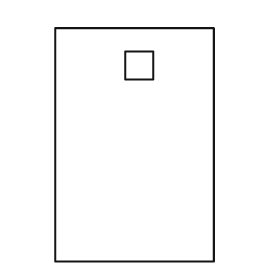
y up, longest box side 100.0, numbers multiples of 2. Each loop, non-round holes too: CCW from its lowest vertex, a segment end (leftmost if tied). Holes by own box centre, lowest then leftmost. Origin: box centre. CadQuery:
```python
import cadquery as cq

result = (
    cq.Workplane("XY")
    .moveTo(-34.0, -50.0)
    .lineTo(34.0, -50.0)
    .lineTo(34.0, 50.0)
    .lineTo(-34.0, 50.0)
    .close()
    .moveTo(-4.0, 28.0)
    .lineTo(8.0, 28.0)
    .lineTo(8.0, 40.0)
    .lineTo(-4.0, 40.0)
    .close()
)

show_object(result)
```